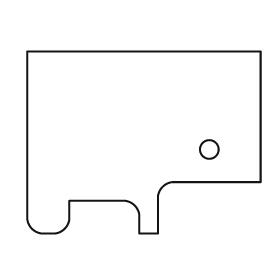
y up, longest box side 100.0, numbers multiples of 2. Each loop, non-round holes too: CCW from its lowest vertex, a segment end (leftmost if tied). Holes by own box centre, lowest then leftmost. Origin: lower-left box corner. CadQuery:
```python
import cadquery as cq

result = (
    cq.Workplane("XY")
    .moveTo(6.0, 0.0)
    .lineTo(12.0, 0.0)
    .threePointArc((16.0, 2.0), (18.0, 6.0))
    .lineTo(18.0, 14.0)
    .lineTo(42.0, 14.0)
    .threePointArc((46.0, 12.0), (48.0, 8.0))
    .lineTo(48.0, 0.0)
    .lineTo(56.0, 0.0)
    .lineTo(56.0, 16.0)
    .threePointArc((58.0, 20.0), (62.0, 22.0))
    .lineTo(100.0, 22.0)
    .lineTo(100.0, 78.0)
    .lineTo(0.0, 78.0)
    .lineTo(0.0, 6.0)
    .threePointArc((2.0, 2.0), (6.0, 0.0))
    .close()
    .moveTo(78.0, 36.0)
    .circle(4.0)
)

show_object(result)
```